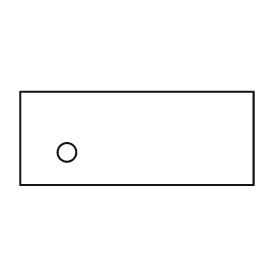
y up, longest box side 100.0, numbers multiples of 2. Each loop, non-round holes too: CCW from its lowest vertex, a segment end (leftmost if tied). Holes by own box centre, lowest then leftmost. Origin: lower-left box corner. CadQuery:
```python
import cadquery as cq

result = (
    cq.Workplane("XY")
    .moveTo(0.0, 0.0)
    .lineTo(100.0, 0.0)
    .lineTo(100.0, 40.0)
    .lineTo(0.0, 40.0)
    .close()
    .moveTo(20.0, 14.0)
    .circle(4.0)
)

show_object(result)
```